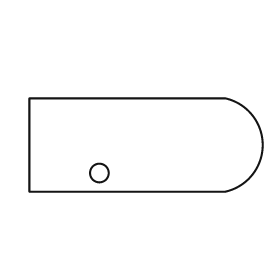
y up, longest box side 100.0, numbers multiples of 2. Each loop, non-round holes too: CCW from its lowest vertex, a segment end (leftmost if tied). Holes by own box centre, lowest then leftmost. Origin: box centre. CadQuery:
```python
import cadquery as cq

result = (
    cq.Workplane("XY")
    .moveTo(-50.0, -20.0)
    .lineTo(34.0, -20.0)
    .threePointArc((50.0, 0.0), (34.0, 20.0))
    .lineTo(-50.0, 20.0)
    .close()
    .moveTo(-20.0, -12.0)
    .circle(4.0)
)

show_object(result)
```